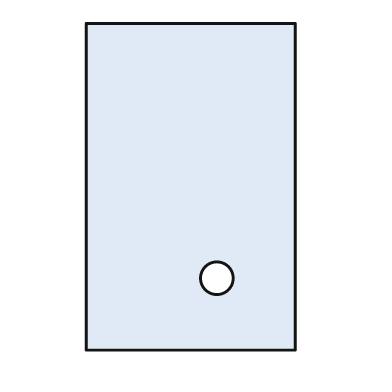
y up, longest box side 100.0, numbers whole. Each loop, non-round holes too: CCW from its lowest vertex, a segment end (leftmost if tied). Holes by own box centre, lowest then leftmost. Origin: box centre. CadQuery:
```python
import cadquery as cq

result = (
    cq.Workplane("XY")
    .moveTo(-32.0, -50.0)
    .lineTo(32.0, -50.0)
    .lineTo(32.0, 50.0)
    .lineTo(-32.0, 50.0)
    .close()
    .moveTo(8.0, -28.0)
    .circle(5.0)
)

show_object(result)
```